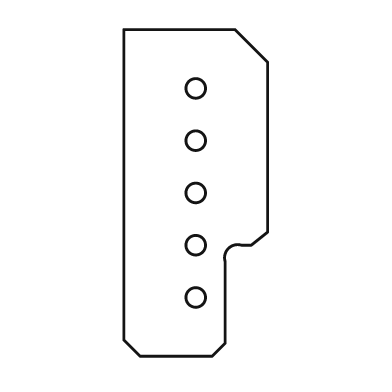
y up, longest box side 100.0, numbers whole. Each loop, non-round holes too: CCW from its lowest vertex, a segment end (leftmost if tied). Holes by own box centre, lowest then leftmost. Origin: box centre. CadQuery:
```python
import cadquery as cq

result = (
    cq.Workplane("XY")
    .moveTo(-17.0, -50.0)
    .lineTo(5.0, -50.0)
    .lineTo(9.0, -46.0)
    .lineTo(9.0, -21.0)
    .threePointArc((10.0, -17.0), (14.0, -16.0))
    .lineTo(17.0, -16.0)
    .lineTo(22.0, -12.0)
    .lineTo(22.0, 40.0)
    .lineTo(12.0, 50.0)
    .lineTo(-22.0, 50.0)
    .lineTo(-22.0, -45.0)
    .close()
    .moveTo(0.0, -32.0)
    .circle(3.0)
    .moveTo(0.0, -16.0)
    .circle(3.0)
    .moveTo(0.0, 0.0)
    .circle(3.0)
    .moveTo(0.0, 16.0)
    .circle(3.0)
    .moveTo(0.0, 32.0)
    .circle(3.0)
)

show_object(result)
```